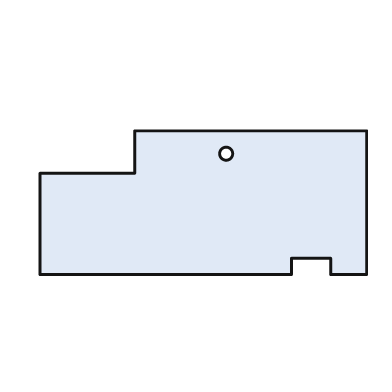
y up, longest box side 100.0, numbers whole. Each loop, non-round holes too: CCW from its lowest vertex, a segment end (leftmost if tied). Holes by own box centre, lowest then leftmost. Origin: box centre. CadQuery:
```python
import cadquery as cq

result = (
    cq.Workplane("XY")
    .moveTo(-50.0, -22.0)
    .lineTo(27.0, -22.0)
    .lineTo(27.0, -17.0)
    .lineTo(39.0, -17.0)
    .lineTo(39.0, -22.0)
    .lineTo(50.0, -22.0)
    .lineTo(50.0, 22.0)
    .lineTo(-21.0, 22.0)
    .lineTo(-21.0, 9.0)
    .lineTo(-50.0, 9.0)
    .close()
    .moveTo(7.0, 15.0)
    .circle(2.0)
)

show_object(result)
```